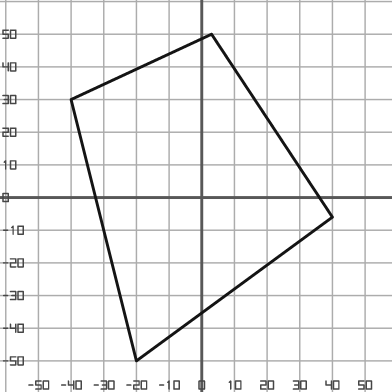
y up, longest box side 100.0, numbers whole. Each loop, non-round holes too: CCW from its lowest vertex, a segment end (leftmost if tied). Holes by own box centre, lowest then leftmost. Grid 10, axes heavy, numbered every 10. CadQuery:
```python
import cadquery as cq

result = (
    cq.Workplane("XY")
    .moveTo(-20.0, -50.0)
    .lineTo(40.0, -6.0)
    .lineTo(3.0, 50.0)
    .lineTo(-40.0, 30.0)
    .close()
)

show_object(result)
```